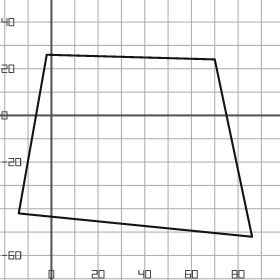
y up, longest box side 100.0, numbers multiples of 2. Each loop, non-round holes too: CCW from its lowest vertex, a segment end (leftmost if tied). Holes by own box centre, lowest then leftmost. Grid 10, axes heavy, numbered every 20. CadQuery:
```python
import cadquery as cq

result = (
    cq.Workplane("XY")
    .moveTo(86.0, -52.0)
    .lineTo(70.0, 24.0)
    .lineTo(-2.0, 26.0)
    .lineTo(-14.0, -42.0)
    .close()
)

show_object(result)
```